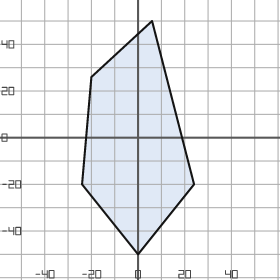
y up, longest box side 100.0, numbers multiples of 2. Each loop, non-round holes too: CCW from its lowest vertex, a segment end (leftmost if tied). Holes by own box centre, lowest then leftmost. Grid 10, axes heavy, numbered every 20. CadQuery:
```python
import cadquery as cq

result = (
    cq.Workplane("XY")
    .moveTo(0.0, -50.0)
    .lineTo(24.0, -20.0)
    .lineTo(6.0, 50.0)
    .lineTo(-20.0, 26.0)
    .lineTo(-24.0, -20.0)
    .close()
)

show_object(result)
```